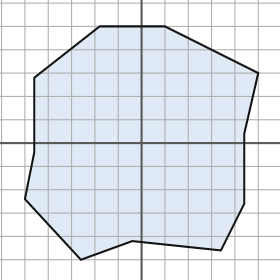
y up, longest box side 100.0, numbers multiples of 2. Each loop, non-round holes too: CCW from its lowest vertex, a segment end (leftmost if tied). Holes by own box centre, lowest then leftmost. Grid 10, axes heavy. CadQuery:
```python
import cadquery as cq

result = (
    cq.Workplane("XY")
    .moveTo(-26.0, -50.0)
    .lineTo(-4.0, -42.0)
    .lineTo(34.0, -46.0)
    .lineTo(44.0, -26.0)
    .lineTo(44.0, 4.0)
    .lineTo(50.0, 30.0)
    .lineTo(10.0, 50.0)
    .lineTo(-18.0, 50.0)
    .lineTo(-46.0, 28.0)
    .lineTo(-46.0, -4.0)
    .lineTo(-50.0, -24.0)
    .close()
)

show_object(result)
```